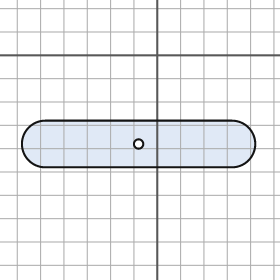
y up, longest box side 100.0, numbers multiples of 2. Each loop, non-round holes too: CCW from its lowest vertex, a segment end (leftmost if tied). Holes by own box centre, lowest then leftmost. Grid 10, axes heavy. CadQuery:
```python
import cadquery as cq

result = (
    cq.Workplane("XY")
    .moveTo(-48.0, -48.0)
    .lineTo(32.0, -48.0)
    .threePointArc((42.0, -38.0), (32.0, -28.0))
    .lineTo(-48.0, -28.0)
    .threePointArc((-58.0, -38.0), (-48.0, -48.0))
    .close()
    .moveTo(-8.0, -38.0)
    .circle(2.0)
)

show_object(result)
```